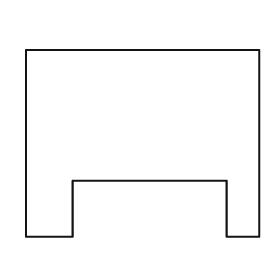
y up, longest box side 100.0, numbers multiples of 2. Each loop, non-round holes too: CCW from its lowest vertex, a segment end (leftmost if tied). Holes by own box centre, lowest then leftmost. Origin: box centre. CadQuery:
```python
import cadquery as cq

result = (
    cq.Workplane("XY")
    .moveTo(-50.0, -40.0)
    .lineTo(-30.0, -40.0)
    .lineTo(-30.0, -16.0)
    .lineTo(36.0, -16.0)
    .lineTo(36.0, -40.0)
    .lineTo(50.0, -40.0)
    .lineTo(50.0, 40.0)
    .lineTo(-50.0, 40.0)
    .close()
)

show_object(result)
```